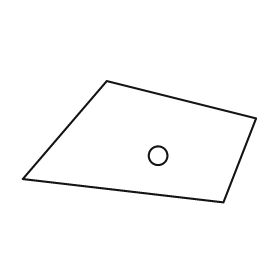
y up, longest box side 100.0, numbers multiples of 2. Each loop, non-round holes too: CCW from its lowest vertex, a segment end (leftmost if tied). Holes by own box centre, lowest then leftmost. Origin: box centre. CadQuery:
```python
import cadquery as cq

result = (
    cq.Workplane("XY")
    .moveTo(36.0, -26.0)
    .lineTo(50.0, 10.0)
    .lineTo(-14.0, 26.0)
    .lineTo(-50.0, -16.0)
    .close()
    .moveTo(8.0, -6.0)
    .circle(4.0)
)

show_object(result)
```